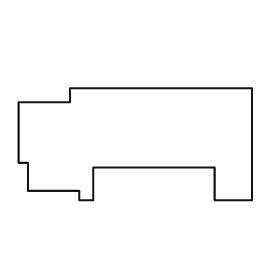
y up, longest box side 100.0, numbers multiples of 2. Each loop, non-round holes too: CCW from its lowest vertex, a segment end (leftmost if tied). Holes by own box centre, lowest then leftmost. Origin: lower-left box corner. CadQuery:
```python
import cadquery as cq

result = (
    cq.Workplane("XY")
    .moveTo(26.0, 0.0)
    .lineTo(32.0, 0.0)
    .lineTo(32.0, 14.0)
    .lineTo(84.0, 14.0)
    .lineTo(84.0, 0.0)
    .lineTo(100.0, 0.0)
    .lineTo(100.0, 48.0)
    .lineTo(22.0, 48.0)
    .lineTo(22.0, 42.0)
    .lineTo(0.0, 42.0)
    .lineTo(0.0, 16.0)
    .lineTo(4.0, 16.0)
    .lineTo(4.0, 4.0)
    .lineTo(26.0, 4.0)
    .close()
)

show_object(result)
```